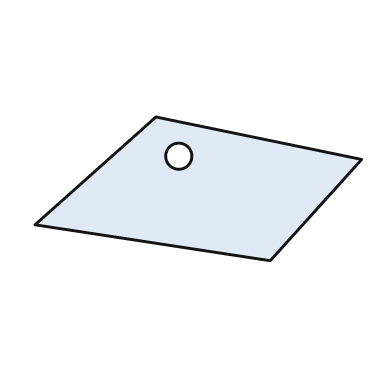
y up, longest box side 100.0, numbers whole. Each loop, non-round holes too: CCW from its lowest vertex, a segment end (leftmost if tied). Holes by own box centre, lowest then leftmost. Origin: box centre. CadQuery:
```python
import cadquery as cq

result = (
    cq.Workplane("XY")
    .moveTo(22.0, -22.0)
    .lineTo(50.0, 9.0)
    .lineTo(-13.0, 22.0)
    .lineTo(-50.0, -11.0)
    .close()
    .moveTo(-6.0, 10.0)
    .circle(4.0)
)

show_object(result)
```